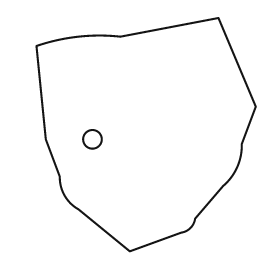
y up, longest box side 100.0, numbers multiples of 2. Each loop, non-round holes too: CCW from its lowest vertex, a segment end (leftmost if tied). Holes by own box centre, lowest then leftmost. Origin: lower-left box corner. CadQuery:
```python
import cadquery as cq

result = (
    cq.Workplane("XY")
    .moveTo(40.0, 0.0)
    .lineTo(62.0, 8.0)
    .threePointArc((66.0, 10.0), (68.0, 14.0))
    .lineTo(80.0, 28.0)
    .threePointArc((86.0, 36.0), (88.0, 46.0))
    .lineTo(94.0, 62.0)
    .lineTo(78.0, 100.0)
    .lineTo(36.0, 92.0)
    .threePointArc((18.0, 92.0), (0.0, 88.0))
    .lineTo(4.0, 48.0)
    .lineTo(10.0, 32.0)
    .threePointArc((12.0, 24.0), (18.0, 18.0))
    .close()
    .moveTo(24.0, 48.0)
    .circle(4.0)
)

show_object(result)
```